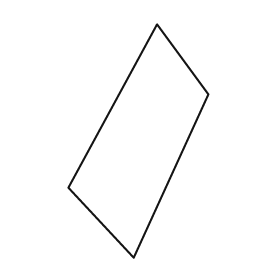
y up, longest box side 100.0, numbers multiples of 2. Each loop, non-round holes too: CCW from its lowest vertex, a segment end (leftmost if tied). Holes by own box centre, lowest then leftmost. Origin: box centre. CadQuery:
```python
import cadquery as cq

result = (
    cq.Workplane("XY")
    .moveTo(-2.0, -50.0)
    .lineTo(30.0, 20.0)
    .lineTo(8.0, 50.0)
    .lineTo(-30.0, -20.0)
    .close()
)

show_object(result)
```